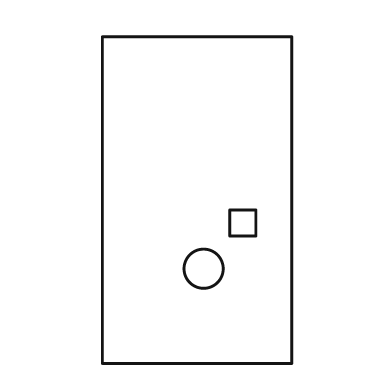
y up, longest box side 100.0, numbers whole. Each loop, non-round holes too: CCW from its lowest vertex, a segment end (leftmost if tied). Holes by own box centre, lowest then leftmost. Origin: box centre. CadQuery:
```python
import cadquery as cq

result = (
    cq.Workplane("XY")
    .moveTo(-29.0, -50.0)
    .lineTo(29.0, -50.0)
    .lineTo(29.0, 50.0)
    .lineTo(-29.0, 50.0)
    .close()
    .moveTo(2.0, -21.0)
    .circle(6.0)
    .moveTo(10.0, -11.0)
    .lineTo(18.0, -11.0)
    .lineTo(18.0, -3.0)
    .lineTo(10.0, -3.0)
    .close()
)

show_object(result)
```